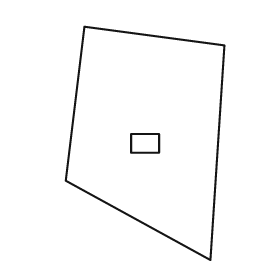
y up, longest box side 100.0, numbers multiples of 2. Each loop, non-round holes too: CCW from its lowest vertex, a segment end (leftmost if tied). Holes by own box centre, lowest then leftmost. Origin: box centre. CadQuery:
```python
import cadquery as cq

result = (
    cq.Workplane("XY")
    .moveTo(28.0, -50.0)
    .lineTo(34.0, 42.0)
    .lineTo(-26.0, 50.0)
    .lineTo(-34.0, -16.0)
    .close()
    .moveTo(-6.0, -4.0)
    .lineTo(6.0, -4.0)
    .lineTo(6.0, 4.0)
    .lineTo(-6.0, 4.0)
    .close()
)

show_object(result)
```